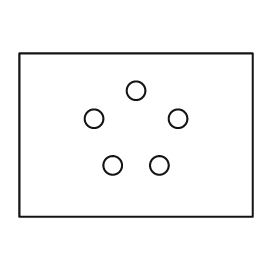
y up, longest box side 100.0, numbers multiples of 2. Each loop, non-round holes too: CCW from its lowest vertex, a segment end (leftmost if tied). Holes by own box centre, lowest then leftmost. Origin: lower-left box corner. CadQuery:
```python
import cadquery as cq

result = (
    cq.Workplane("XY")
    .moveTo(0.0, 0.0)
    .lineTo(100.0, 0.0)
    .lineTo(100.0, 70.0)
    .lineTo(0.0, 70.0)
    .close()
    .moveTo(40.0, 22.0)
    .circle(4.0)
    .moveTo(60.0, 22.0)
    .circle(4.0)
    .moveTo(32.0, 42.0)
    .circle(4.0)
    .moveTo(68.0, 42.0)
    .circle(4.0)
    .moveTo(50.0, 54.0)
    .circle(4.0)
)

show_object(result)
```